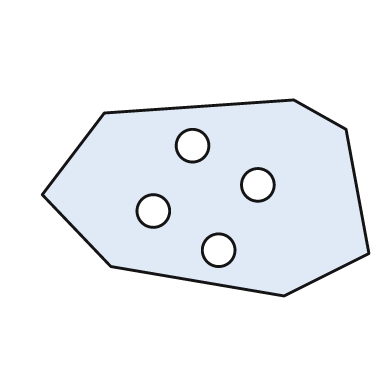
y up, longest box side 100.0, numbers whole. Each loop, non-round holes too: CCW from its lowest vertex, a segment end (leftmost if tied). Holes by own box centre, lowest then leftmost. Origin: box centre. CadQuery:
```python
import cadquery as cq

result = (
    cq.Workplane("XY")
    .moveTo(24.0, -30.0)
    .lineTo(50.0, -17.0)
    .lineTo(43.0, 21.0)
    .lineTo(27.0, 30.0)
    .lineTo(-31.0, 26.0)
    .lineTo(-50.0, 1.0)
    .lineTo(-29.0, -21.0)
    .close()
    .moveTo(4.0, -16.0)
    .circle(5.0)
    .moveTo(-16.0, -4.0)
    .circle(5.0)
    .moveTo(16.0, 4.0)
    .circle(5.0)
    .moveTo(-4.0, 16.0)
    .circle(5.0)
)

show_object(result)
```